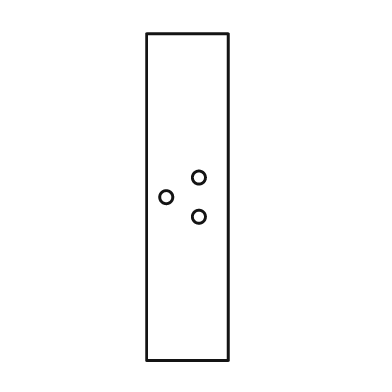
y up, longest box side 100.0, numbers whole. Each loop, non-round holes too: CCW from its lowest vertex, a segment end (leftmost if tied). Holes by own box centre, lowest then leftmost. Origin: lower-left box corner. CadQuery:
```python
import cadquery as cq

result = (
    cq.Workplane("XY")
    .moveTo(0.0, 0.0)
    .lineTo(25.0, 0.0)
    .lineTo(25.0, 100.0)
    .lineTo(0.0, 100.0)
    .close()
    .moveTo(16.0, 44.0)
    .circle(2.0)
    .moveTo(6.0, 50.0)
    .circle(2.0)
    .moveTo(16.0, 56.0)
    .circle(2.0)
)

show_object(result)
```